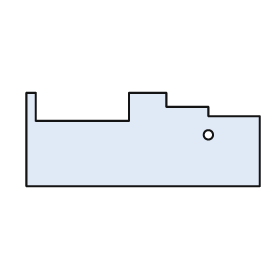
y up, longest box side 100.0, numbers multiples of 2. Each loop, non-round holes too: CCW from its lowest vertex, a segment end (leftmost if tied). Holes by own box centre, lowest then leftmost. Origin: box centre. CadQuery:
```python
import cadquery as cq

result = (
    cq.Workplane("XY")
    .moveTo(-50.0, -20.0)
    .lineTo(50.0, -20.0)
    .lineTo(50.0, 10.0)
    .lineTo(28.0, 10.0)
    .lineTo(28.0, 14.0)
    .lineTo(10.0, 14.0)
    .lineTo(10.0, 20.0)
    .lineTo(-6.0, 20.0)
    .lineTo(-6.0, 8.0)
    .lineTo(-46.0, 8.0)
    .lineTo(-46.0, 20.0)
    .lineTo(-50.0, 20.0)
    .close()
    .moveTo(28.0, 2.0)
    .circle(2.0)
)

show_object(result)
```